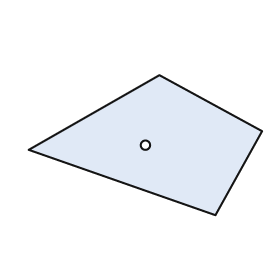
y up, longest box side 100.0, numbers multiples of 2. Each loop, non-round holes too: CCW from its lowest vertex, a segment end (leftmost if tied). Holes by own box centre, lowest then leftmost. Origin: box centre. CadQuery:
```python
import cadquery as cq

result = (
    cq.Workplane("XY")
    .moveTo(30.0, -30.0)
    .lineTo(50.0, 6.0)
    .lineTo(6.0, 30.0)
    .lineTo(-50.0, -2.0)
    .close()
    .moveTo(0.0, 0.0)
    .circle(2.0)
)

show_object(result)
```